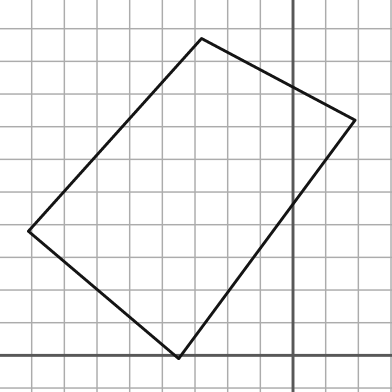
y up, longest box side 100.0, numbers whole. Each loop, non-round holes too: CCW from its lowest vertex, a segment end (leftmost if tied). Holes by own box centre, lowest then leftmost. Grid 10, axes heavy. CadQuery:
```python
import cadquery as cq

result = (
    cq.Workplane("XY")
    .moveTo(-35.0, -1.0)
    .lineTo(19.0, 72.0)
    .lineTo(-28.0, 97.0)
    .lineTo(-81.0, 38.0)
    .close()
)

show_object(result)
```